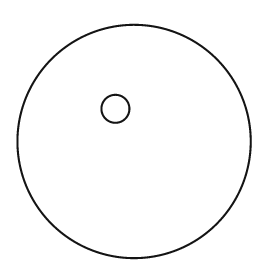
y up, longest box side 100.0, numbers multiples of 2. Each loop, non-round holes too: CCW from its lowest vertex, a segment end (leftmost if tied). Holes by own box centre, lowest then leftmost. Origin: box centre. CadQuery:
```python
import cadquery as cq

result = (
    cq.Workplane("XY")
    .moveTo(0.0, 0.0)
    .circle(50.0)
    .moveTo(-8.0, 14.0)
    .circle(6.0)
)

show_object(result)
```